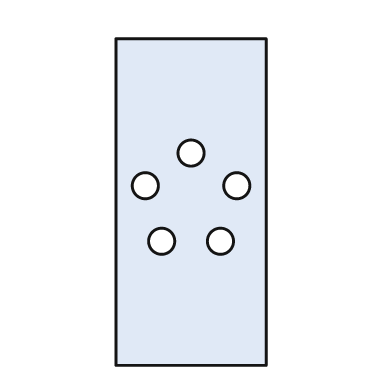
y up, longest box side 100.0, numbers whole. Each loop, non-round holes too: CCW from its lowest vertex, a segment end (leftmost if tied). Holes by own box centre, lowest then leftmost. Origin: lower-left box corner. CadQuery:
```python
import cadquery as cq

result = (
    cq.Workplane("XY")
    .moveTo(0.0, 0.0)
    .lineTo(46.0, 0.0)
    .lineTo(46.0, 100.0)
    .lineTo(0.0, 100.0)
    .close()
    .moveTo(14.0, 38.0)
    .circle(4.0)
    .moveTo(32.0, 38.0)
    .circle(4.0)
    .moveTo(9.0, 55.0)
    .circle(4.0)
    .moveTo(37.0, 55.0)
    .circle(4.0)
    .moveTo(23.0, 65.0)
    .circle(4.0)
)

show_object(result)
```